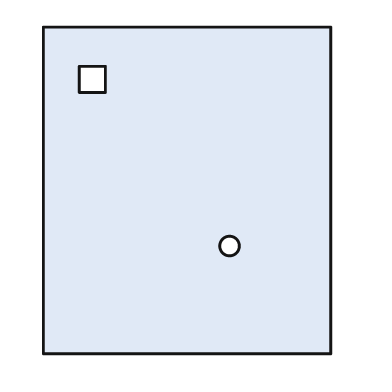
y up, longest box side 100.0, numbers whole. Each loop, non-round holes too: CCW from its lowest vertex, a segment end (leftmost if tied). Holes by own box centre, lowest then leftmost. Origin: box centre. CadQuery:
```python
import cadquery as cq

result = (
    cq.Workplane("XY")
    .moveTo(-44.0, -50.0)
    .lineTo(44.0, -50.0)
    .lineTo(44.0, 50.0)
    .lineTo(-44.0, 50.0)
    .close()
    .moveTo(13.0, -17.0)
    .circle(3.0)
    .moveTo(-33.0, 30.0)
    .lineTo(-25.0, 30.0)
    .lineTo(-25.0, 38.0)
    .lineTo(-33.0, 38.0)
    .close()
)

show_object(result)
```